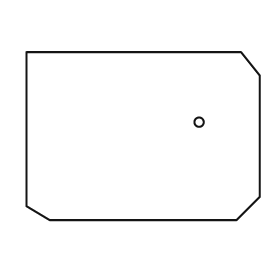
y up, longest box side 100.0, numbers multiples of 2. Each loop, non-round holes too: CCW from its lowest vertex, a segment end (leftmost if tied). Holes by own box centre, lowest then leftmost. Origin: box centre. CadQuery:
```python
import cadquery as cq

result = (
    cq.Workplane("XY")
    .moveTo(-40.0, -36.0)
    .lineTo(40.0, -36.0)
    .lineTo(50.0, -26.0)
    .lineTo(50.0, 26.0)
    .lineTo(42.0, 36.0)
    .lineTo(-50.0, 36.0)
    .lineTo(-50.0, -30.0)
    .close()
    .moveTo(24.0, 6.0)
    .circle(2.0)
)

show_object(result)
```